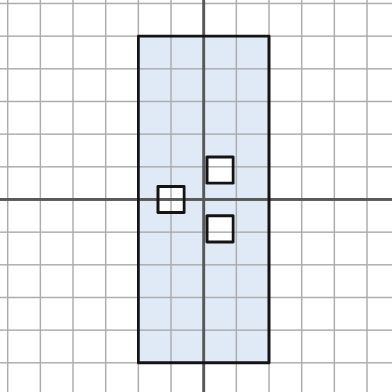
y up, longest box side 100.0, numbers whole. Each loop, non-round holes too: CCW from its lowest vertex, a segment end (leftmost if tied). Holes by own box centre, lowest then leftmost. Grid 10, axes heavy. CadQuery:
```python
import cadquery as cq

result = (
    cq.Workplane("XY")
    .moveTo(-20.0, -50.0)
    .lineTo(20.0, -50.0)
    .lineTo(20.0, 50.0)
    .lineTo(-20.0, 50.0)
    .close()
    .moveTo(1.0, -13.0)
    .lineTo(9.0, -13.0)
    .lineTo(9.0, -5.0)
    .lineTo(1.0, -5.0)
    .close()
    .moveTo(-14.0, -4.0)
    .lineTo(-6.0, -4.0)
    .lineTo(-6.0, 4.0)
    .lineTo(-14.0, 4.0)
    .close()
    .moveTo(1.0, 5.0)
    .lineTo(9.0, 5.0)
    .lineTo(9.0, 13.0)
    .lineTo(1.0, 13.0)
    .close()
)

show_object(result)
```